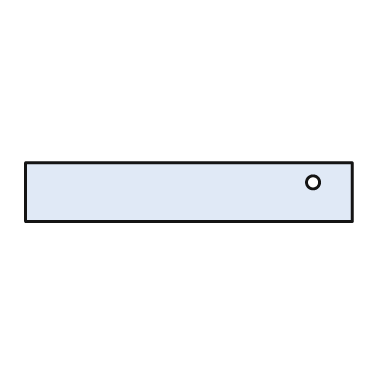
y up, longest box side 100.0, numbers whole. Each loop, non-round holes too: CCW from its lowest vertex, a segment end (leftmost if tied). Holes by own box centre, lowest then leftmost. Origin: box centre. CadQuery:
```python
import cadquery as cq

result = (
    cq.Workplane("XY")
    .moveTo(-50.0, -9.0)
    .lineTo(50.0, -9.0)
    .lineTo(50.0, 9.0)
    .lineTo(-50.0, 9.0)
    .close()
    .moveTo(38.0, 3.0)
    .circle(2.0)
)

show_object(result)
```